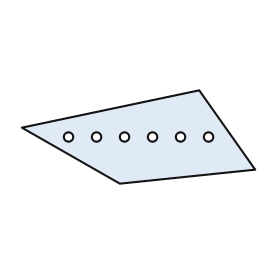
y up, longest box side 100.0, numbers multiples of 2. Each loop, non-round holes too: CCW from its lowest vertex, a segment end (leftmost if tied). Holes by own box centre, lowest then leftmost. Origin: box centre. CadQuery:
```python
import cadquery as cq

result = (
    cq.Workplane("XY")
    .moveTo(-8.0, -20.0)
    .lineTo(50.0, -14.0)
    .lineTo(26.0, 20.0)
    .lineTo(-50.0, 4.0)
    .close()
    .moveTo(-30.0, 0.0)
    .circle(2.0)
    .moveTo(-18.0, 0.0)
    .circle(2.0)
    .moveTo(-6.0, 0.0)
    .circle(2.0)
    .moveTo(6.0, 0.0)
    .circle(2.0)
    .moveTo(18.0, 0.0)
    .circle(2.0)
    .moveTo(30.0, 0.0)
    .circle(2.0)
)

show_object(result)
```